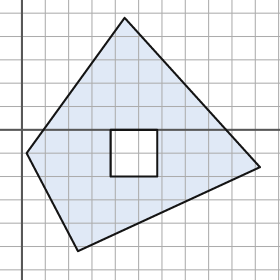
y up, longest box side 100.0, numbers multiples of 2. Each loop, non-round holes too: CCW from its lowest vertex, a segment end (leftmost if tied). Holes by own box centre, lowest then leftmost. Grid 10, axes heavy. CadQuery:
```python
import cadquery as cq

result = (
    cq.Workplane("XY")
    .moveTo(24.0, -52.0)
    .lineTo(102.0, -16.0)
    .lineTo(44.0, 48.0)
    .lineTo(2.0, -10.0)
    .close()
    .moveTo(38.0, -20.0)
    .lineTo(58.0, -20.0)
    .lineTo(58.0, 0.0)
    .lineTo(38.0, 0.0)
    .close()
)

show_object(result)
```